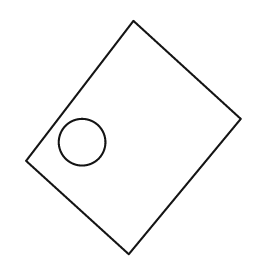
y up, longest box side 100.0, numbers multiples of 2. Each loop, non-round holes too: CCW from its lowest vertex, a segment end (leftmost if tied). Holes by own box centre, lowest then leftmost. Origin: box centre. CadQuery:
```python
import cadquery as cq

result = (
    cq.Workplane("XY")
    .moveTo(-2.0, -50.0)
    .lineTo(46.0, 8.0)
    .lineTo(0.0, 50.0)
    .lineTo(-46.0, -10.0)
    .close()
    .moveTo(-22.0, -2.0)
    .circle(10.0)
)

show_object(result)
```